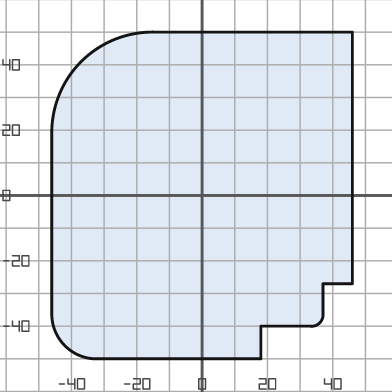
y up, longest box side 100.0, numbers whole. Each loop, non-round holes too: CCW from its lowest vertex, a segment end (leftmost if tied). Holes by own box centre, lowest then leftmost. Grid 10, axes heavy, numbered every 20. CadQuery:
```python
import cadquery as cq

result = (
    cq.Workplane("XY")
    .moveTo(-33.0, -50.0)
    .lineTo(18.0, -50.0)
    .lineTo(18.0, -40.0)
    .lineTo(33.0, -40.0)
    .threePointArc((36.0, -39.0), (37.0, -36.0))
    .lineTo(37.0, -27.0)
    .lineTo(46.0, -27.0)
    .lineTo(46.0, 50.0)
    .lineTo(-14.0, 50.0)
    .threePointArc((-37.0, 41.0), (-46.0, 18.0))
    .lineTo(-46.0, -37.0)
    .threePointArc((-42.0, -46.0), (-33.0, -50.0))
    .close()
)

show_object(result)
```